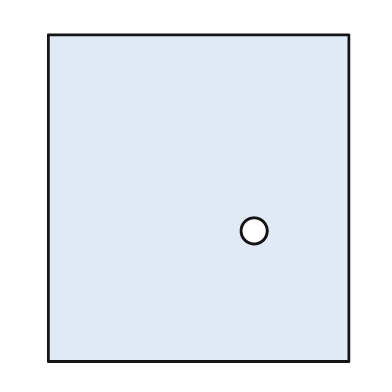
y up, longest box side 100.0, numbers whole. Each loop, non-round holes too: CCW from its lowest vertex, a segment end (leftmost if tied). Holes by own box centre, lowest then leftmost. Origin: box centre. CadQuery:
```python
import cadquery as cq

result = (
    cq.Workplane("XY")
    .moveTo(-46.0, -50.0)
    .lineTo(46.0, -50.0)
    .lineTo(46.0, 50.0)
    .lineTo(-46.0, 50.0)
    .close()
    .moveTo(17.0, -10.0)
    .circle(4.0)
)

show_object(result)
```